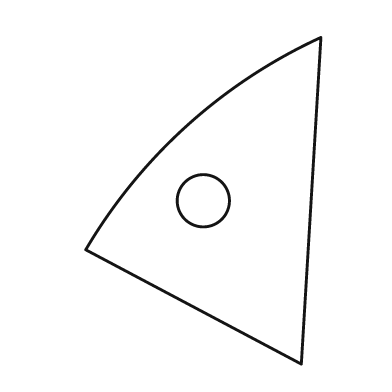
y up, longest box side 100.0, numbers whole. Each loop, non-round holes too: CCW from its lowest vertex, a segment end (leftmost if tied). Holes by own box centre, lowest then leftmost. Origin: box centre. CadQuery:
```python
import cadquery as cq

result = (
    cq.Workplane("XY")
    .moveTo(30.0, -50.0)
    .lineTo(36.0, 50.0)
    .threePointArc((-5.0, 23.0), (-36.0, -15.0))
    .close()
    .moveTo(0.0, 0.0)
    .circle(8.0)
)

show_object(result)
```